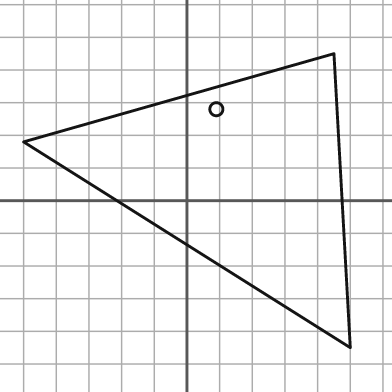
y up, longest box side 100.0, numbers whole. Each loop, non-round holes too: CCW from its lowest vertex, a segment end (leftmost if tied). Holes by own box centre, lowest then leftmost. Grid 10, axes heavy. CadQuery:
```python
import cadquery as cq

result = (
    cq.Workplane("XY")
    .moveTo(50.0, -45.0)
    .lineTo(45.0, 45.0)
    .lineTo(-50.0, 18.0)
    .close()
    .moveTo(9.0, 28.0)
    .circle(2.0)
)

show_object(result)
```